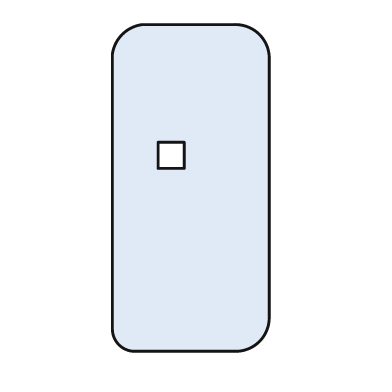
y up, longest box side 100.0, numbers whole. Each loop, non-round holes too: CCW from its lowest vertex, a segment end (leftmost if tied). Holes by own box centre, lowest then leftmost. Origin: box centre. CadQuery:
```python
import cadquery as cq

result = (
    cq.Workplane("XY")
    .moveTo(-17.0, -50.0)
    .lineTo(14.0, -50.0)
    .threePointArc((21.0, -47.0), (24.0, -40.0))
    .lineTo(24.0, 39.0)
    .threePointArc((21.0, 47.0), (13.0, 50.0))
    .lineTo(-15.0, 50.0)
    .threePointArc((-21.0, 47.0), (-24.0, 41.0))
    .lineTo(-24.0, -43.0)
    .threePointArc((-22.0, -48.0), (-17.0, -50.0))
    .close()
    .moveTo(-10.0, 6.0)
    .lineTo(-2.0, 6.0)
    .lineTo(-2.0, 14.0)
    .lineTo(-10.0, 14.0)
    .close()
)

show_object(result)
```